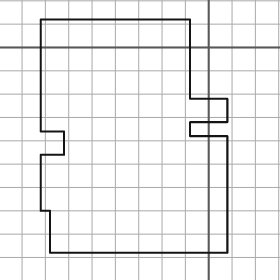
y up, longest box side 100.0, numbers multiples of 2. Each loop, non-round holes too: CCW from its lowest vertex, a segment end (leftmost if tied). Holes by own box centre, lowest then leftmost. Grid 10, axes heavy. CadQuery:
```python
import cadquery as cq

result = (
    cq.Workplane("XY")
    .moveTo(-68.0, -88.0)
    .lineTo(8.0, -88.0)
    .lineTo(8.0, -38.0)
    .lineTo(-8.0, -38.0)
    .lineTo(-8.0, -32.0)
    .lineTo(8.0, -32.0)
    .lineTo(8.0, -22.0)
    .lineTo(-8.0, -22.0)
    .lineTo(-8.0, 12.0)
    .lineTo(-72.0, 12.0)
    .lineTo(-72.0, -36.0)
    .lineTo(-62.0, -36.0)
    .lineTo(-62.0, -46.0)
    .lineTo(-72.0, -46.0)
    .lineTo(-72.0, -70.0)
    .lineTo(-68.0, -70.0)
    .close()
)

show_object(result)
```